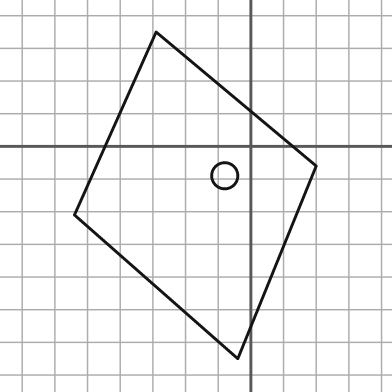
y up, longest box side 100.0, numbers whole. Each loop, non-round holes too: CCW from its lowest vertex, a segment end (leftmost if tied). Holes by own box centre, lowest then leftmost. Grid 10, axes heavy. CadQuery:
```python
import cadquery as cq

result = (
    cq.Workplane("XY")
    .moveTo(-4.0, -65.0)
    .lineTo(20.0, -6.0)
    .lineTo(-29.0, 35.0)
    .lineTo(-54.0, -21.0)
    .close()
    .moveTo(-8.0, -9.0)
    .circle(4.0)
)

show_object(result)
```